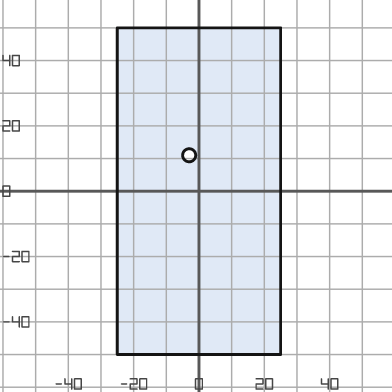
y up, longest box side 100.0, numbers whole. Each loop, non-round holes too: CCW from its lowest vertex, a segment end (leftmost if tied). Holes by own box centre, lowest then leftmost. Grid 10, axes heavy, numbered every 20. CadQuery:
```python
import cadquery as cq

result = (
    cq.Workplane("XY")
    .moveTo(-25.0, -50.0)
    .lineTo(25.0, -50.0)
    .lineTo(25.0, 50.0)
    .lineTo(-25.0, 50.0)
    .close()
    .moveTo(-3.0, 11.0)
    .circle(2.0)
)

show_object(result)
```